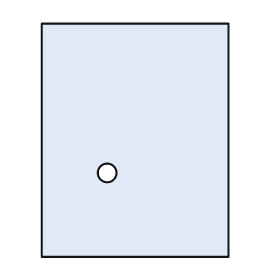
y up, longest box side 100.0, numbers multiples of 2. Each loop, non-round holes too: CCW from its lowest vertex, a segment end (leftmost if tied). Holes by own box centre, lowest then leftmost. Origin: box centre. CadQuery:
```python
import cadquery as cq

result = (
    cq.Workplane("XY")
    .moveTo(-40.0, -50.0)
    .lineTo(40.0, -50.0)
    .lineTo(40.0, 50.0)
    .lineTo(-40.0, 50.0)
    .close()
    .moveTo(-12.0, -14.0)
    .circle(4.0)
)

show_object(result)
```